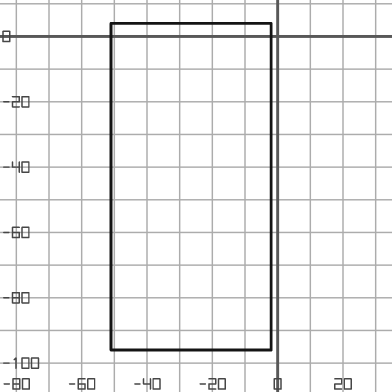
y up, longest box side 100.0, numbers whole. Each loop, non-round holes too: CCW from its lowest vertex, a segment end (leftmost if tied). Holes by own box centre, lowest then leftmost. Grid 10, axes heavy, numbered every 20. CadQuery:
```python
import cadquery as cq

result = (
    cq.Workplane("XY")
    .moveTo(-51.0, -96.0)
    .lineTo(-2.0, -96.0)
    .lineTo(-2.0, 4.0)
    .lineTo(-51.0, 4.0)
    .close()
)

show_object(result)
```